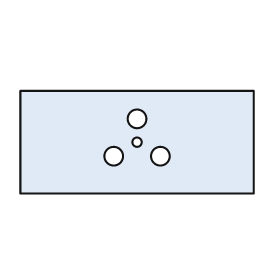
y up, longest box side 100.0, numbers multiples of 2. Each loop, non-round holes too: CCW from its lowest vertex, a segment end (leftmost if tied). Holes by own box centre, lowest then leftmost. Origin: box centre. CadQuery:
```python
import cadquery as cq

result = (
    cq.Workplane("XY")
    .moveTo(-50.0, -22.0)
    .lineTo(50.0, -22.0)
    .lineTo(50.0, 22.0)
    .lineTo(-50.0, 22.0)
    .close()
    .moveTo(-10.0, -6.0)
    .circle(4.0)
    .moveTo(10.0, -6.0)
    .circle(4.0)
    .moveTo(0.0, 0.0)
    .circle(2.0)
    .moveTo(0.0, 10.0)
    .circle(4.0)
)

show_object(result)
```